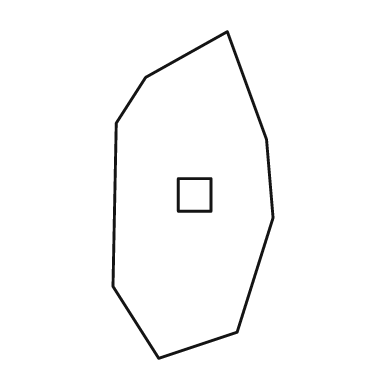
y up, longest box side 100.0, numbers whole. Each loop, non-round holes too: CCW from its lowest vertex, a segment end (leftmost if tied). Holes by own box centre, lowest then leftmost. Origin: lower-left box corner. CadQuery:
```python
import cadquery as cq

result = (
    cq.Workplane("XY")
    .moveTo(14.0, 0.0)
    .lineTo(38.0, 8.0)
    .lineTo(49.0, 43.0)
    .lineTo(47.0, 67.0)
    .lineTo(35.0, 100.0)
    .lineTo(10.0, 86.0)
    .lineTo(1.0, 72.0)
    .lineTo(0.0, 22.0)
    .close()
    .moveTo(20.0, 45.0)
    .lineTo(30.0, 45.0)
    .lineTo(30.0, 55.0)
    .lineTo(20.0, 55.0)
    .close()
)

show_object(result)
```